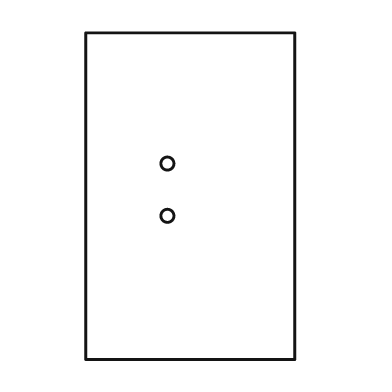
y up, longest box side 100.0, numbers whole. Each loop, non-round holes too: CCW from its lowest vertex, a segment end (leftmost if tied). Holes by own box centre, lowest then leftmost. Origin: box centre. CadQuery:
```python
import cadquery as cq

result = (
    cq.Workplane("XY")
    .moveTo(-32.0, -50.0)
    .lineTo(32.0, -50.0)
    .lineTo(32.0, 50.0)
    .lineTo(-32.0, 50.0)
    .close()
    .moveTo(-7.0, -6.0)
    .circle(2.0)
    .moveTo(-7.0, 10.0)
    .circle(2.0)
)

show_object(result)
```